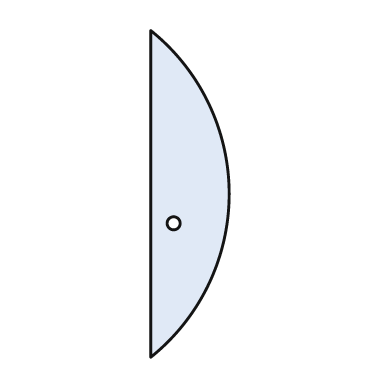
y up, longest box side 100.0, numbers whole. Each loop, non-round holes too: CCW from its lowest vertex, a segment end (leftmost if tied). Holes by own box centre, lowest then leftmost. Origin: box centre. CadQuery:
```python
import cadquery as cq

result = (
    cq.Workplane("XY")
    .moveTo(-12.0, -50.0)
    .threePointArc((12.0, 0.0), (-12.0, 50.0))
    .close()
    .moveTo(-5.0, -9.0)
    .circle(2.0)
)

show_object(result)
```